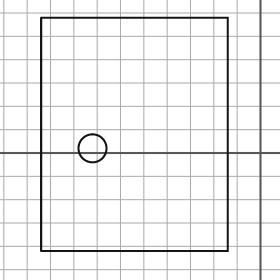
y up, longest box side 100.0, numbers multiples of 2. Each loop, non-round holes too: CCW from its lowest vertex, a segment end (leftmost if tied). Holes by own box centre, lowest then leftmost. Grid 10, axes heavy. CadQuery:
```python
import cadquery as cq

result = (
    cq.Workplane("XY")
    .moveTo(-94.0, -42.0)
    .lineTo(-14.0, -42.0)
    .lineTo(-14.0, 58.0)
    .lineTo(-94.0, 58.0)
    .close()
    .moveTo(-72.0, 2.0)
    .circle(6.0)
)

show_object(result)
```